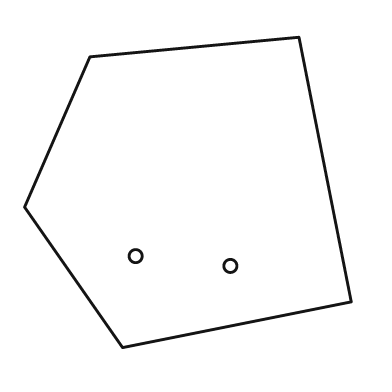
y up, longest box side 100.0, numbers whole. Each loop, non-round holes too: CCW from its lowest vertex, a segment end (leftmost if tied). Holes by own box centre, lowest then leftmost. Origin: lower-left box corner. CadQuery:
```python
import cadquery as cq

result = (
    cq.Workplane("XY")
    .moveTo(30.0, 0.0)
    .lineTo(100.0, 14.0)
    .lineTo(84.0, 95.0)
    .lineTo(20.0, 89.0)
    .lineTo(0.0, 43.0)
    .close()
    .moveTo(63.0, 25.0)
    .circle(2.0)
    .moveTo(34.0, 28.0)
    .circle(2.0)
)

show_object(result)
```